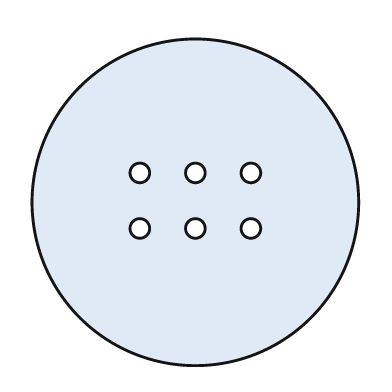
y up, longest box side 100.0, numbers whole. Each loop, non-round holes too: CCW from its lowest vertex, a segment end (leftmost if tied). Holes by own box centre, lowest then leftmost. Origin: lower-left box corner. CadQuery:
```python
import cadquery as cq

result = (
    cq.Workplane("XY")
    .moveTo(50.0, 50.0)
    .circle(50.0)
    .moveTo(33.0, 42.0)
    .circle(3.0)
    .moveTo(50.0, 42.0)
    .circle(3.0)
    .moveTo(67.0, 42.0)
    .circle(3.0)
    .moveTo(33.0, 59.0)
    .circle(3.0)
    .moveTo(50.0, 59.0)
    .circle(3.0)
    .moveTo(67.0, 59.0)
    .circle(3.0)
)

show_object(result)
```